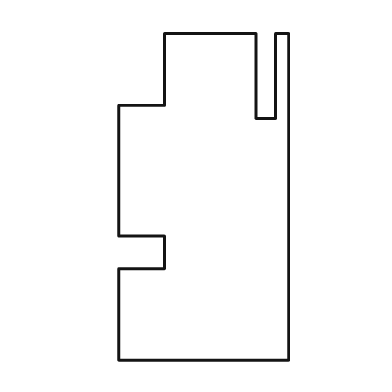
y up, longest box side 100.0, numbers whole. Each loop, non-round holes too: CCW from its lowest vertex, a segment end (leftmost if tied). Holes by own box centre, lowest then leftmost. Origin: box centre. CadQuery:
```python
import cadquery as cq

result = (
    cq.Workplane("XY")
    .moveTo(-26.0, -50.0)
    .lineTo(26.0, -50.0)
    .lineTo(26.0, 50.0)
    .lineTo(22.0, 50.0)
    .lineTo(22.0, 24.0)
    .lineTo(16.0, 24.0)
    .lineTo(16.0, 50.0)
    .lineTo(-12.0, 50.0)
    .lineTo(-12.0, 28.0)
    .lineTo(-26.0, 28.0)
    .lineTo(-26.0, -12.0)
    .lineTo(-12.0, -12.0)
    .lineTo(-12.0, -22.0)
    .lineTo(-26.0, -22.0)
    .close()
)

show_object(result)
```